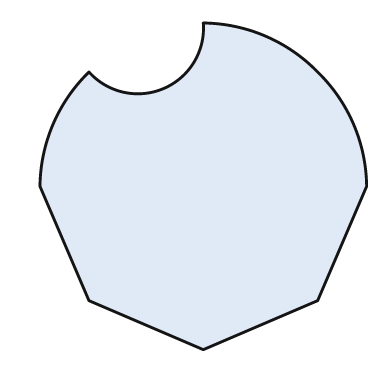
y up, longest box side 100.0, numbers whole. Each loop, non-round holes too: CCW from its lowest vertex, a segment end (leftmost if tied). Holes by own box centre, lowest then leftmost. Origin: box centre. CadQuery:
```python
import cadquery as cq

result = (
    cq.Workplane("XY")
    .moveTo(0.0, -50.0)
    .lineTo(35.0, -35.0)
    .lineTo(50.0, 0.0)
    .threePointArc((46.0, 19.0), (35.0, 35.0))
    .threePointArc((19.0, 46.0), (0.0, 50.0))
    .threePointArc((-12.0, 30.0), (-35.0, 35.0))
    .threePointArc((-46.0, 19.0), (-50.0, 0.0))
    .lineTo(-35.0, -35.0)
    .close()
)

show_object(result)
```